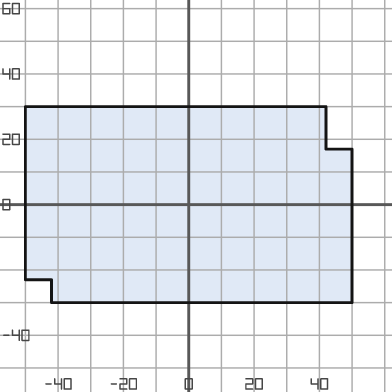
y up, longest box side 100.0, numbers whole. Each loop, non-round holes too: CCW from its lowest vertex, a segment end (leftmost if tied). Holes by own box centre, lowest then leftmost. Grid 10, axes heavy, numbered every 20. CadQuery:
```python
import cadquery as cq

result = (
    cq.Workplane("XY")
    .moveTo(-42.0, -30.0)
    .lineTo(50.0, -30.0)
    .lineTo(50.0, 17.0)
    .lineTo(42.0, 17.0)
    .lineTo(42.0, 30.0)
    .lineTo(-50.0, 30.0)
    .lineTo(-50.0, -23.0)
    .lineTo(-42.0, -23.0)
    .close()
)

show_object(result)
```